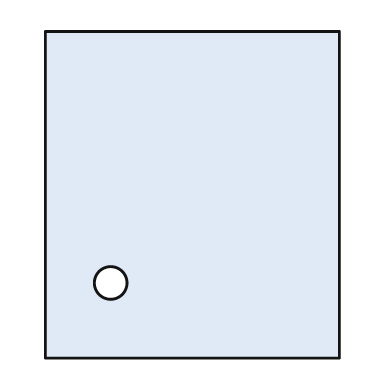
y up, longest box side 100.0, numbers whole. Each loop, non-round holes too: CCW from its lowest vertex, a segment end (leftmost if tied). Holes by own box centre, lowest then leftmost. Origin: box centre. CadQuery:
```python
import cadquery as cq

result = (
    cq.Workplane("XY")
    .moveTo(-45.0, -50.0)
    .lineTo(45.0, -50.0)
    .lineTo(45.0, 50.0)
    .lineTo(-45.0, 50.0)
    .close()
    .moveTo(-25.0, -27.0)
    .circle(5.0)
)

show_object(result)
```